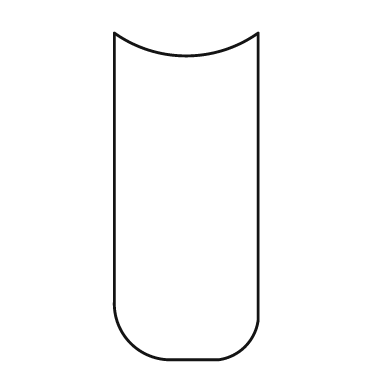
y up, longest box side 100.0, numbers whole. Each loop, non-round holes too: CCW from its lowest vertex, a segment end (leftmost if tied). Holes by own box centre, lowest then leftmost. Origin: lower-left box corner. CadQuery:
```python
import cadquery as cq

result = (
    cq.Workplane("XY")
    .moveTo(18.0, 0.0)
    .lineTo(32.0, 0.0)
    .threePointArc((40.0, 4.0), (44.0, 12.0))
    .lineTo(44.0, 100.0)
    .threePointArc((22.0, 93.0), (0.0, 100.0))
    .lineTo(0.0, 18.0)
    .threePointArc((5.0, 5.0), (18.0, 0.0))
    .close()
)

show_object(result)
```